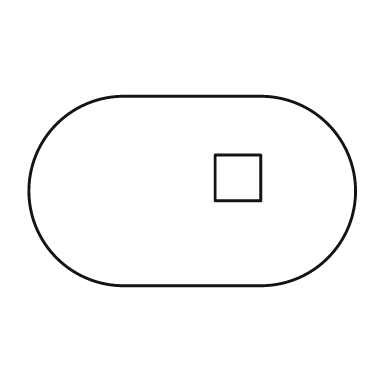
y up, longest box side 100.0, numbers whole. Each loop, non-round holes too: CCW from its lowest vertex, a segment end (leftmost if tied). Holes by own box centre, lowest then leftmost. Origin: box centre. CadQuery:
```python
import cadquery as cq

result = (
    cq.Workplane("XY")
    .moveTo(-21.0, -29.0)
    .lineTo(21.0, -29.0)
    .threePointArc((50.0, 0.0), (21.0, 29.0))
    .lineTo(-21.0, 29.0)
    .threePointArc((-50.0, 0.0), (-21.0, -29.0))
    .close()
    .moveTo(7.0, -3.0)
    .lineTo(21.0, -3.0)
    .lineTo(21.0, 11.0)
    .lineTo(7.0, 11.0)
    .close()
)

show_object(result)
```